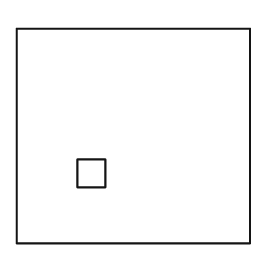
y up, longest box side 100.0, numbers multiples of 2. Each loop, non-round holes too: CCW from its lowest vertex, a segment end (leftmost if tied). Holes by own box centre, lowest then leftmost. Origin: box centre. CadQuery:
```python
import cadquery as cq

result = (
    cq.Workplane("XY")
    .moveTo(-50.0, -46.0)
    .lineTo(50.0, -46.0)
    .lineTo(50.0, 46.0)
    .lineTo(-50.0, 46.0)
    .close()
    .moveTo(-24.0, -22.0)
    .lineTo(-12.0, -22.0)
    .lineTo(-12.0, -10.0)
    .lineTo(-24.0, -10.0)
    .close()
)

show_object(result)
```